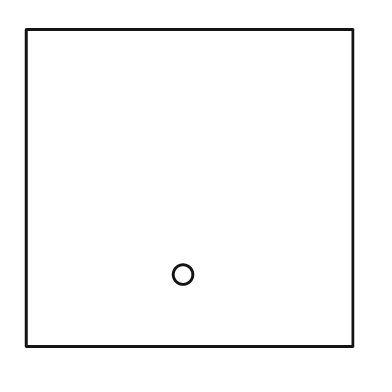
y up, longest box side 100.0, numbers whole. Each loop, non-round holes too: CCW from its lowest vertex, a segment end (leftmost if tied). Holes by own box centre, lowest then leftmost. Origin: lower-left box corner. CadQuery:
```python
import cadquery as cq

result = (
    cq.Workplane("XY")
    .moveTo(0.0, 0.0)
    .lineTo(100.0, 0.0)
    .lineTo(100.0, 97.0)
    .lineTo(0.0, 97.0)
    .close()
    .moveTo(48.0, 22.0)
    .circle(3.0)
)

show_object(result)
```